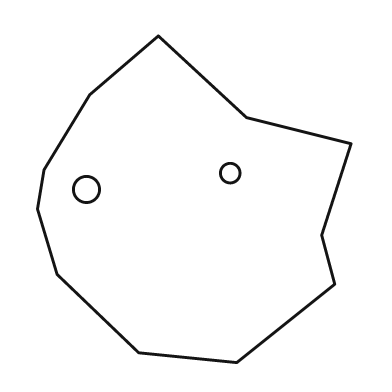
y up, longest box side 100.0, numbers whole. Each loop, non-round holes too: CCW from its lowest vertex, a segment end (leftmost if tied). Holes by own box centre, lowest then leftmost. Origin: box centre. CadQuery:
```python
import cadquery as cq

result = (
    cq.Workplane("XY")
    .moveTo(13.0, -50.0)
    .lineTo(43.0, -26.0)
    .lineTo(39.0, -11.0)
    .lineTo(48.0, 17.0)
    .lineTo(16.0, 25.0)
    .lineTo(-11.0, 50.0)
    .lineTo(-32.0, 32.0)
    .lineTo(-46.0, 9.0)
    .lineTo(-48.0, -3.0)
    .lineTo(-42.0, -23.0)
    .lineTo(-17.0, -47.0)
    .close()
    .moveTo(-33.0, 3.0)
    .circle(4.0)
    .moveTo(11.0, 8.0)
    .circle(3.0)
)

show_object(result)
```